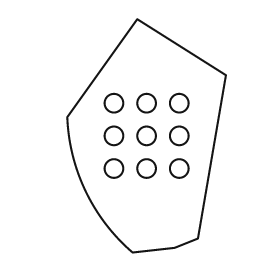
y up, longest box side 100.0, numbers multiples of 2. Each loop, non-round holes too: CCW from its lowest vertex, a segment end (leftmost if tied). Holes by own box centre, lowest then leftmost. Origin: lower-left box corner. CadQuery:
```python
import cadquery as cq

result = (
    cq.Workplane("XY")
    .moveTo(28.0, 0.0)
    .lineTo(46.0, 2.0)
    .lineTo(56.0, 6.0)
    .lineTo(68.0, 76.0)
    .lineTo(30.0, 100.0)
    .lineTo(0.0, 58.0)
    .threePointArc((8.0, 26.0), (28.0, 0.0))
    .close()
    .moveTo(20.0, 36.0)
    .circle(4.0)
    .moveTo(34.0, 36.0)
    .circle(4.0)
    .moveTo(48.0, 36.0)
    .circle(4.0)
    .moveTo(20.0, 50.0)
    .circle(4.0)
    .moveTo(34.0, 50.0)
    .circle(4.0)
    .moveTo(48.0, 50.0)
    .circle(4.0)
    .moveTo(20.0, 64.0)
    .circle(4.0)
    .moveTo(34.0, 64.0)
    .circle(4.0)
    .moveTo(48.0, 64.0)
    .circle(4.0)
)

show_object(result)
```